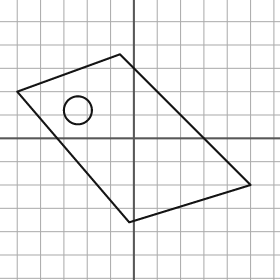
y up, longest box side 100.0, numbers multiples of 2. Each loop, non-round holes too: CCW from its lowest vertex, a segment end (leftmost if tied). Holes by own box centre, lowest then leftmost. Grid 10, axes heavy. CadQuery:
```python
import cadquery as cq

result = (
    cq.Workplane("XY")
    .moveTo(-2.0, -36.0)
    .lineTo(50.0, -20.0)
    .lineTo(-6.0, 36.0)
    .lineTo(-50.0, 20.0)
    .close()
    .moveTo(-24.0, 12.0)
    .circle(6.0)
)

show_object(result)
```